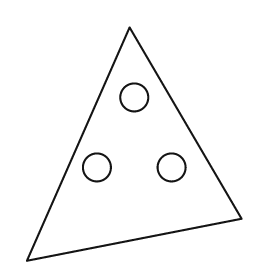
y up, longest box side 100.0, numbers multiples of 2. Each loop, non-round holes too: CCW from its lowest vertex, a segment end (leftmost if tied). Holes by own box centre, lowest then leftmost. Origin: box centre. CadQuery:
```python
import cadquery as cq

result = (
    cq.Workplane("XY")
    .moveTo(-46.0, -50.0)
    .lineTo(46.0, -32.0)
    .lineTo(-2.0, 50.0)
    .close()
    .moveTo(-16.0, -10.0)
    .circle(6.0)
    .moveTo(16.0, -10.0)
    .circle(6.0)
    .moveTo(0.0, 20.0)
    .circle(6.0)
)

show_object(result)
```